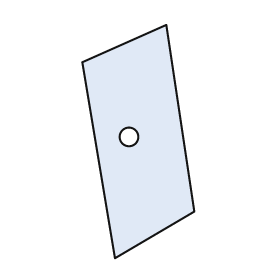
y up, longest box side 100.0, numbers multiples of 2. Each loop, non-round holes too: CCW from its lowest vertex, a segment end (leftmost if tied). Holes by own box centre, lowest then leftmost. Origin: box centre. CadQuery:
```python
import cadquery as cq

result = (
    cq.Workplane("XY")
    .moveTo(-10.0, -50.0)
    .lineTo(24.0, -30.0)
    .lineTo(12.0, 50.0)
    .lineTo(-24.0, 34.0)
    .close()
    .moveTo(-4.0, 2.0)
    .circle(4.0)
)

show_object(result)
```